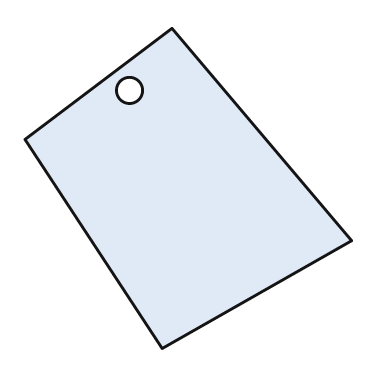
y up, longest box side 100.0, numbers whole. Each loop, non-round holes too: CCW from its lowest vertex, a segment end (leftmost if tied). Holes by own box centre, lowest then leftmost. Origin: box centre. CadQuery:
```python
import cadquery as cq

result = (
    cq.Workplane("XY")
    .moveTo(-8.0, -49.0)
    .lineTo(50.0, -16.0)
    .lineTo(-5.0, 49.0)
    .lineTo(-50.0, 15.0)
    .close()
    .moveTo(-18.0, 30.0)
    .circle(4.0)
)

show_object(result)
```